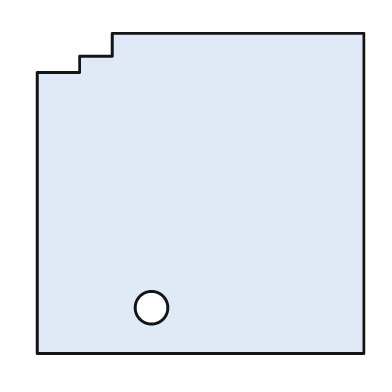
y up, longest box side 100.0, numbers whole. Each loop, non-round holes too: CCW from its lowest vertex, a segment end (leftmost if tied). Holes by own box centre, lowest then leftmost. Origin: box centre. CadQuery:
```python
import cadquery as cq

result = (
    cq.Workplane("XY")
    .moveTo(-50.0, -49.0)
    .lineTo(50.0, -49.0)
    .lineTo(50.0, 49.0)
    .lineTo(-27.0, 49.0)
    .lineTo(-27.0, 42.0)
    .lineTo(-37.0, 42.0)
    .lineTo(-37.0, 37.0)
    .lineTo(-50.0, 37.0)
    .close()
    .moveTo(-15.0, -35.0)
    .circle(5.0)
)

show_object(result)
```